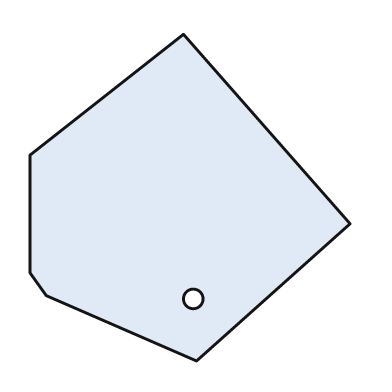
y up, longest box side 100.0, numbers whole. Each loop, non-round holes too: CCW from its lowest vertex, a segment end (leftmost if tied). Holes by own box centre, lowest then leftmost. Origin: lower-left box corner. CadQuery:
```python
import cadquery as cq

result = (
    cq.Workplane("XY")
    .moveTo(51.0, 0.0)
    .lineTo(98.0, 42.0)
    .lineTo(47.0, 100.0)
    .lineTo(0.0, 63.0)
    .lineTo(0.0, 27.0)
    .lineTo(5.0, 20.0)
    .close()
    .moveTo(50.0, 19.0)
    .circle(3.0)
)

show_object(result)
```